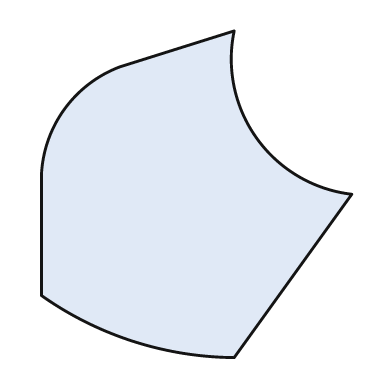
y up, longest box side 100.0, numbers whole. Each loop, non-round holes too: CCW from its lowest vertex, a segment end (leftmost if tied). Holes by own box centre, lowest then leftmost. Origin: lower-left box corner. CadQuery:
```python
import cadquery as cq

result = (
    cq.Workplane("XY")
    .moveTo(59.0, 0.0)
    .lineTo(95.0, 50.0)
    .threePointArc((66.0, 67.0), (59.0, 100.0))
    .lineTo(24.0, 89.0)
    .threePointArc((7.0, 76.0), (0.0, 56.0))
    .lineTo(0.0, 19.0)
    .threePointArc((28.0, 5.0), (59.0, 0.0))
    .close()
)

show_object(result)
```